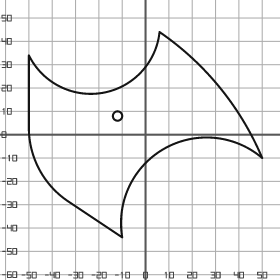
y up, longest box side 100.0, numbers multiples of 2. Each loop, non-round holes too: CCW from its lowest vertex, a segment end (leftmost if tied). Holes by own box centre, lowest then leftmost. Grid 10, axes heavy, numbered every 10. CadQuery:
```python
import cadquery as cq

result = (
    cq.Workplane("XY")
    .moveTo(-10.0, -44.0)
    .threePointArc((8.0, -6.0), (50.0, -10.0))
    .threePointArc((32.0, 20.0), (6.0, 44.0))
    .threePointArc((-18.0, 18.0), (-50.0, 34.0))
    .lineTo(-50.0, 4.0)
    .threePointArc((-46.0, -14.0), (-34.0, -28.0))
    .close()
    .moveTo(-12.0, 8.0)
    .circle(2.0)
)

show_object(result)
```